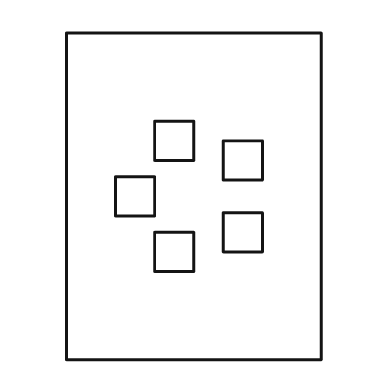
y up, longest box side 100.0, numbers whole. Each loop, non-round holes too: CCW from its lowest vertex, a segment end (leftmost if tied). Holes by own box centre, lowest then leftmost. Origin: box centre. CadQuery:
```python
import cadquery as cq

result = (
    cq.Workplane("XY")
    .moveTo(-39.0, -50.0)
    .lineTo(39.0, -50.0)
    .lineTo(39.0, 50.0)
    .lineTo(-39.0, 50.0)
    .close()
    .moveTo(-12.0, -23.0)
    .lineTo(0.0, -23.0)
    .lineTo(0.0, -11.0)
    .lineTo(-12.0, -11.0)
    .close()
    .moveTo(9.0, -17.0)
    .lineTo(21.0, -17.0)
    .lineTo(21.0, -5.0)
    .lineTo(9.0, -5.0)
    .close()
    .moveTo(-24.0, -6.0)
    .lineTo(-12.0, -6.0)
    .lineTo(-12.0, 6.0)
    .lineTo(-24.0, 6.0)
    .close()
    .moveTo(9.0, 5.0)
    .lineTo(21.0, 5.0)
    .lineTo(21.0, 17.0)
    .lineTo(9.0, 17.0)
    .close()
    .moveTo(-12.0, 11.0)
    .lineTo(0.0, 11.0)
    .lineTo(0.0, 23.0)
    .lineTo(-12.0, 23.0)
    .close()
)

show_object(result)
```